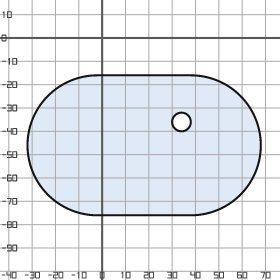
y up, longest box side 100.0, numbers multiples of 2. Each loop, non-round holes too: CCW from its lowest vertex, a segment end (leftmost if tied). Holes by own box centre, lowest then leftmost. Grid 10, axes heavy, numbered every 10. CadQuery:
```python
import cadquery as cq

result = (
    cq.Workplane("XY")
    .moveTo(-2.0, -76.0)
    .lineTo(38.0, -76.0)
    .threePointArc((68.0, -46.0), (38.0, -16.0))
    .lineTo(-2.0, -16.0)
    .threePointArc((-32.0, -46.0), (-2.0, -76.0))
    .close()
    .moveTo(34.0, -36.0)
    .circle(4.0)
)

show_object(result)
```